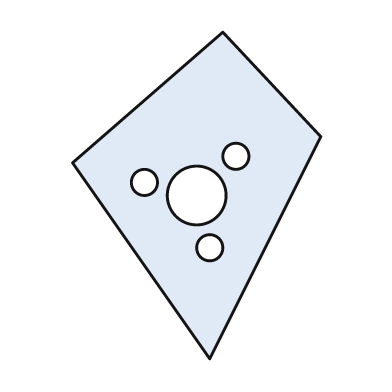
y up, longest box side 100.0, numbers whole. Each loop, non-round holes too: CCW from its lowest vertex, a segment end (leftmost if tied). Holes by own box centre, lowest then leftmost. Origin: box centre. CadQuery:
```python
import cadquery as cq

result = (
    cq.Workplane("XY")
    .moveTo(4.0, -50.0)
    .lineTo(38.0, 18.0)
    .lineTo(8.0, 50.0)
    .lineTo(-38.0, 10.0)
    .close()
    .moveTo(4.0, -16.0)
    .circle(4.0)
    .moveTo(0.0, 0.0)
    .circle(9.0)
    .moveTo(-16.0, 4.0)
    .circle(4.0)
    .moveTo(12.0, 12.0)
    .circle(4.0)
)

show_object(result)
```